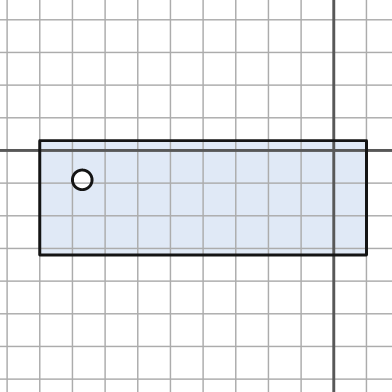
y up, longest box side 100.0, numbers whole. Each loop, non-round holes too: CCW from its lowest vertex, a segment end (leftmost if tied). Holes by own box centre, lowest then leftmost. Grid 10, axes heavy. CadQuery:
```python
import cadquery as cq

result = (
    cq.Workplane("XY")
    .moveTo(-90.0, -32.0)
    .lineTo(10.0, -32.0)
    .lineTo(10.0, 3.0)
    .lineTo(-90.0, 3.0)
    .close()
    .moveTo(-77.0, -9.0)
    .circle(3.0)
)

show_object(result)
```